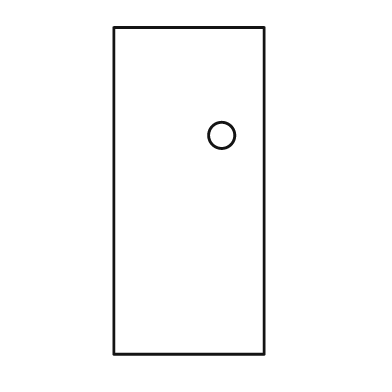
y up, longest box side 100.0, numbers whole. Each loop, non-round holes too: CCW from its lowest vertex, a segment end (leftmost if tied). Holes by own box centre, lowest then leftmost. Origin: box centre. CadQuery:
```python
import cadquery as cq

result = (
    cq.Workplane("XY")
    .moveTo(-23.0, -50.0)
    .lineTo(23.0, -50.0)
    .lineTo(23.0, 50.0)
    .lineTo(-23.0, 50.0)
    .close()
    .moveTo(10.0, 17.0)
    .circle(4.0)
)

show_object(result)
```